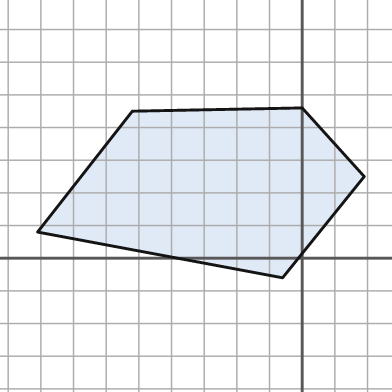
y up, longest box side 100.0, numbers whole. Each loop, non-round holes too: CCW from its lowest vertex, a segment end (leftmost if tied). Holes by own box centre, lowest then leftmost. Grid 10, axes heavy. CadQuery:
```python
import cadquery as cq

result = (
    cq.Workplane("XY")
    .moveTo(-6.0, -6.0)
    .lineTo(19.0, 25.0)
    .lineTo(0.0, 46.0)
    .lineTo(-52.0, 45.0)
    .lineTo(-81.0, 8.0)
    .close()
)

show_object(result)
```